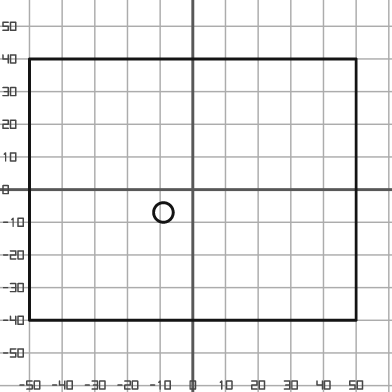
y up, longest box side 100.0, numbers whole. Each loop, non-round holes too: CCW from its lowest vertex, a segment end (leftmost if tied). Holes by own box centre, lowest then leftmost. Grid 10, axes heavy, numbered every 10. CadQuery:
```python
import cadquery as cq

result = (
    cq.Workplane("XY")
    .moveTo(-50.0, -40.0)
    .lineTo(50.0, -40.0)
    .lineTo(50.0, 40.0)
    .lineTo(-50.0, 40.0)
    .close()
    .moveTo(-9.0, -7.0)
    .circle(3.0)
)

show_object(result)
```